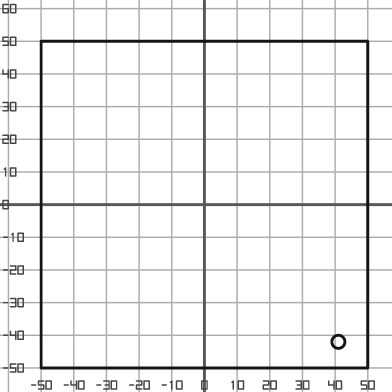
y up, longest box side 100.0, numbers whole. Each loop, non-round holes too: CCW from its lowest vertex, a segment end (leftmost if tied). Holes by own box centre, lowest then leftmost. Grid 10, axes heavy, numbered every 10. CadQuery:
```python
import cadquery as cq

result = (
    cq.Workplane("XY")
    .moveTo(-50.0, -50.0)
    .lineTo(50.0, -50.0)
    .lineTo(50.0, 50.0)
    .lineTo(-50.0, 50.0)
    .close()
    .moveTo(41.0, -42.0)
    .circle(2.0)
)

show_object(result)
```